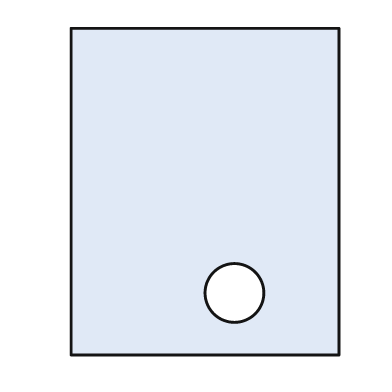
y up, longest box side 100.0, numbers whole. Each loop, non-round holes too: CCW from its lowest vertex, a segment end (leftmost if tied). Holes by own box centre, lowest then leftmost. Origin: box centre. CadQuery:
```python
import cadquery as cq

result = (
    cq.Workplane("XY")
    .moveTo(-41.0, -50.0)
    .lineTo(41.0, -50.0)
    .lineTo(41.0, 50.0)
    .lineTo(-41.0, 50.0)
    .close()
    .moveTo(9.0, -31.0)
    .circle(9.0)
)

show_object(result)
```